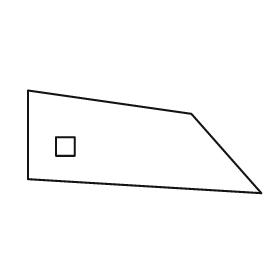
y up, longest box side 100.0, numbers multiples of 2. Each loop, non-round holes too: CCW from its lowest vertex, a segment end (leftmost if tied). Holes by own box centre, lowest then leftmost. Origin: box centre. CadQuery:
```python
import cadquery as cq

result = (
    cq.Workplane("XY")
    .moveTo(50.0, -22.0)
    .lineTo(20.0, 12.0)
    .lineTo(-50.0, 22.0)
    .lineTo(-50.0, -16.0)
    .close()
    .moveTo(-38.0, -6.0)
    .lineTo(-30.0, -6.0)
    .lineTo(-30.0, 2.0)
    .lineTo(-38.0, 2.0)
    .close()
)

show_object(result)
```